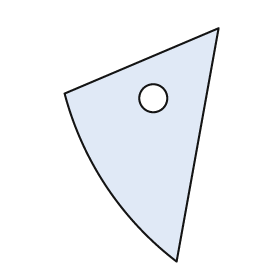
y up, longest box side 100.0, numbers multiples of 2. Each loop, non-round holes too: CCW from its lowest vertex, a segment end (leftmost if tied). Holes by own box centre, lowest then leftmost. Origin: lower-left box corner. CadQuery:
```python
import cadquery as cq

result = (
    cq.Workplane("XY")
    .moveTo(48.0, 0.0)
    .lineTo(66.0, 100.0)
    .lineTo(0.0, 72.0)
    .threePointArc((18.0, 32.0), (48.0, 0.0))
    .close()
    .moveTo(38.0, 70.0)
    .circle(6.0)
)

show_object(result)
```